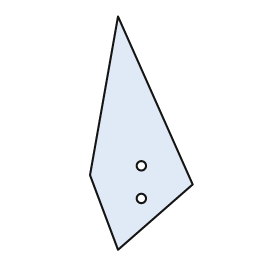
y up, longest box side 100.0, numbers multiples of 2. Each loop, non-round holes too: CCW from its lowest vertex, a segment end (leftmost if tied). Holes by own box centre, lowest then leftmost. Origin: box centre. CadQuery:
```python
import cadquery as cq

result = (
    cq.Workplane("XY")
    .moveTo(-10.0, -50.0)
    .lineTo(22.0, -22.0)
    .lineTo(-10.0, 50.0)
    .lineTo(-22.0, -18.0)
    .close()
    .moveTo(0.0, -28.0)
    .circle(2.0)
    .moveTo(0.0, -14.0)
    .circle(2.0)
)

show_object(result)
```